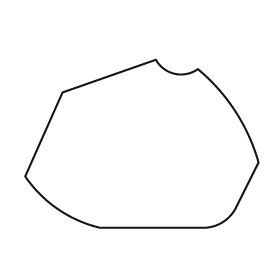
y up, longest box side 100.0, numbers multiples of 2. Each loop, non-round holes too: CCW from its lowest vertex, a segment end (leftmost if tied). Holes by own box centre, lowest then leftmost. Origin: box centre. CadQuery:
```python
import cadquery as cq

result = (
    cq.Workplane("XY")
    .moveTo(-18.0, -36.0)
    .lineTo(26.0, -36.0)
    .threePointArc((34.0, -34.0), (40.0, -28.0))
    .lineTo(50.0, -8.0)
    .threePointArc((40.0, 14.0), (24.0, 32.0))
    .threePointArc((14.0, 30.0), (6.0, 36.0))
    .lineTo(-34.0, 22.0)
    .lineTo(-50.0, -14.0)
    .threePointArc((-36.0, -28.0), (-18.0, -36.0))
    .close()
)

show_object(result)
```